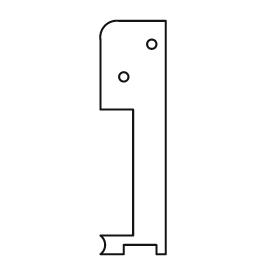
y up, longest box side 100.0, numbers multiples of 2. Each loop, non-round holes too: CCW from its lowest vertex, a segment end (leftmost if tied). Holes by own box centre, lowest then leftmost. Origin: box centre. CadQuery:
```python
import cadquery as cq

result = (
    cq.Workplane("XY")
    .moveTo(-14.0, -50.0)
    .lineTo(-4.0, -50.0)
    .lineTo(-4.0, -46.0)
    .lineTo(10.0, -46.0)
    .lineTo(10.0, -50.0)
    .lineTo(14.0, -50.0)
    .lineTo(14.0, 50.0)
    .lineTo(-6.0, 50.0)
    .threePointArc((-12.0, 48.0), (-14.0, 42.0))
    .lineTo(-14.0, 12.0)
    .lineTo(0.0, 12.0)
    .lineTo(0.0, -42.0)
    .lineTo(-14.0, -42.0)
    .threePointArc((-12.0, -46.0), (-14.0, -50.0))
    .close()
    .moveTo(-4.0, 26.0)
    .circle(2.0)
    .moveTo(8.0, 40.0)
    .circle(2.0)
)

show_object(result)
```